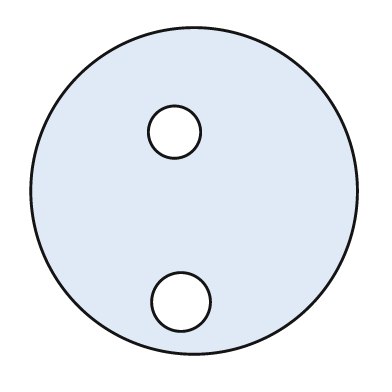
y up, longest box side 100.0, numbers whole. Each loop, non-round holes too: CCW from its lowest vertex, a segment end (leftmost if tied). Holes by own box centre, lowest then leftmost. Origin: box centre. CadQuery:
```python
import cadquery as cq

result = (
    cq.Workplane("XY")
    .moveTo(0.0, 0.0)
    .circle(50.0)
    .moveTo(-4.0, -34.0)
    .circle(9.0)
    .moveTo(-6.0, 18.0)
    .circle(8.0)
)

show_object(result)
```